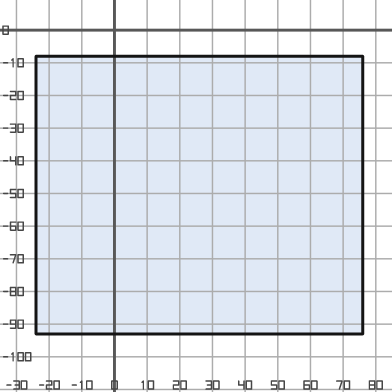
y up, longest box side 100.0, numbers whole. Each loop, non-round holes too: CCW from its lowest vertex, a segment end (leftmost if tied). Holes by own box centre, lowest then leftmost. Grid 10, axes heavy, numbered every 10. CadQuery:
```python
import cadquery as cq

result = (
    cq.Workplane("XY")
    .moveTo(-24.0, -93.0)
    .lineTo(76.0, -93.0)
    .lineTo(76.0, -8.0)
    .lineTo(-24.0, -8.0)
    .close()
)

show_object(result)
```